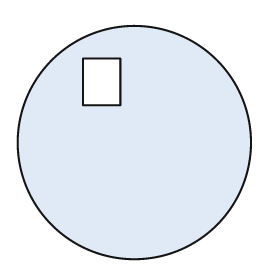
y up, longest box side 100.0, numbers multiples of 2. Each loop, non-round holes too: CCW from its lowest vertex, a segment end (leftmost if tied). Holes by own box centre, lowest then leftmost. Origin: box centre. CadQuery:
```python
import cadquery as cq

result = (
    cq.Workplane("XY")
    .moveTo(0.0, 0.0)
    .circle(50.0)
    .moveTo(-22.0, 16.0)
    .lineTo(-6.0, 16.0)
    .lineTo(-6.0, 36.0)
    .lineTo(-22.0, 36.0)
    .close()
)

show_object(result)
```